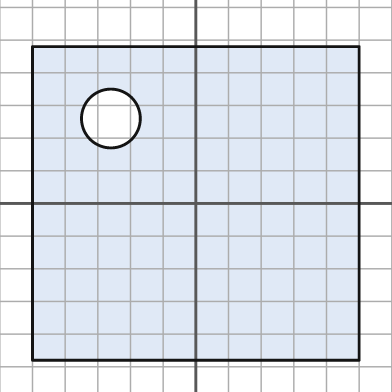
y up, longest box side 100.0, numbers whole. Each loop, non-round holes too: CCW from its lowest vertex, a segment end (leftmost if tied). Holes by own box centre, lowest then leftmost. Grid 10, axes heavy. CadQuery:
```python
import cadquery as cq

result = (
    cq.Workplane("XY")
    .moveTo(-50.0, -48.0)
    .lineTo(50.0, -48.0)
    .lineTo(50.0, 48.0)
    .lineTo(-50.0, 48.0)
    .close()
    .moveTo(-26.0, 26.0)
    .circle(9.0)
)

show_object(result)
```